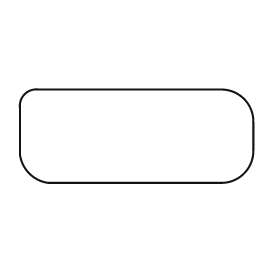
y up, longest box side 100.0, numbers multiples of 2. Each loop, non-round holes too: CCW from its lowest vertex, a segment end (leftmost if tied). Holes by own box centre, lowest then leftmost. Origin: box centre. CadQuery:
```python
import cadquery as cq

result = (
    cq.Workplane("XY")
    .moveTo(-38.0, -20.0)
    .lineTo(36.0, -20.0)
    .threePointArc((46.0, -16.0), (50.0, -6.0))
    .lineTo(50.0, 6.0)
    .threePointArc((46.0, 16.0), (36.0, 20.0))
    .lineTo(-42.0, 20.0)
    .threePointArc((-48.0, 18.0), (-50.0, 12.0))
    .lineTo(-50.0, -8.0)
    .threePointArc((-46.0, -16.0), (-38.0, -20.0))
    .close()
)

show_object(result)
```